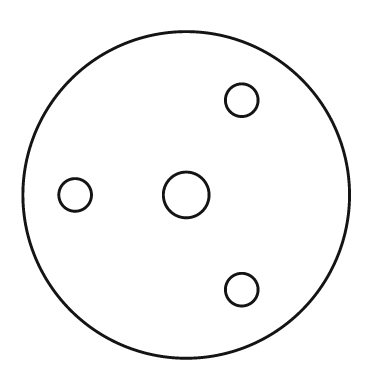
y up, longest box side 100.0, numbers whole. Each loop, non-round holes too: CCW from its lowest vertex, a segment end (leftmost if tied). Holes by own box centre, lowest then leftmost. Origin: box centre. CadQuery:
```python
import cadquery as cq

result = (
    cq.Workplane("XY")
    .moveTo(0.0, 0.0)
    .circle(50.0)
    .moveTo(17.0, -29.0)
    .circle(5.0)
    .moveTo(-34.0, 0.0)
    .circle(5.0)
    .moveTo(0.0, 0.0)
    .circle(7.0)
    .moveTo(17.0, 29.0)
    .circle(5.0)
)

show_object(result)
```